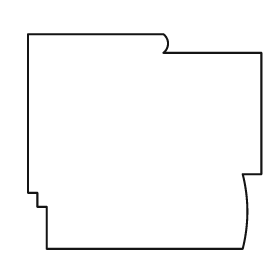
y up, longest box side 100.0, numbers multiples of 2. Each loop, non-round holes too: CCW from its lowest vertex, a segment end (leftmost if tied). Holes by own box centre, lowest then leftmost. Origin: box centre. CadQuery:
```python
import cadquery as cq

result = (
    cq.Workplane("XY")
    .moveTo(-42.0, -46.0)
    .lineTo(42.0, -46.0)
    .threePointArc((44.0, -30.0), (42.0, -14.0))
    .lineTo(50.0, -14.0)
    .lineTo(50.0, 38.0)
    .lineTo(8.0, 38.0)
    .threePointArc((10.0, 42.0), (8.0, 46.0))
    .lineTo(-50.0, 46.0)
    .lineTo(-50.0, -22.0)
    .lineTo(-46.0, -22.0)
    .lineTo(-46.0, -28.0)
    .lineTo(-42.0, -28.0)
    .close()
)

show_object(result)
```